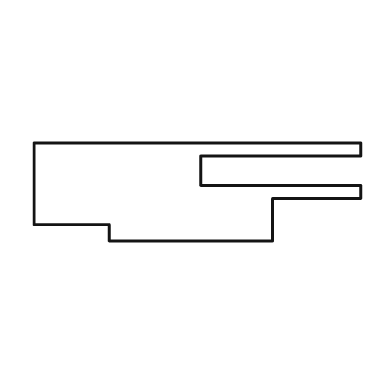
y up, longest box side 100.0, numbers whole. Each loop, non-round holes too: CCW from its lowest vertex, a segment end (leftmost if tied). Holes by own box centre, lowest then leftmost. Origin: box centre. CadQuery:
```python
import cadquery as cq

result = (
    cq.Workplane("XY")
    .moveTo(-27.0, -15.0)
    .lineTo(23.0, -15.0)
    .lineTo(23.0, -2.0)
    .lineTo(50.0, -2.0)
    .lineTo(50.0, 2.0)
    .lineTo(1.0, 2.0)
    .lineTo(1.0, 11.0)
    .lineTo(50.0, 11.0)
    .lineTo(50.0, 15.0)
    .lineTo(-50.0, 15.0)
    .lineTo(-50.0, -10.0)
    .lineTo(-27.0, -10.0)
    .close()
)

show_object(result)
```